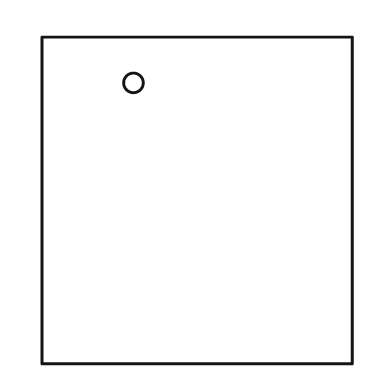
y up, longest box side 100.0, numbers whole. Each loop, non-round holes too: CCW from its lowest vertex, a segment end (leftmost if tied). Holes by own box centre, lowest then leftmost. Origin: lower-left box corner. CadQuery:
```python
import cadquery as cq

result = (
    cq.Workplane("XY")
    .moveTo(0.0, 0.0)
    .lineTo(95.0, 0.0)
    .lineTo(95.0, 100.0)
    .lineTo(0.0, 100.0)
    .close()
    .moveTo(28.0, 86.0)
    .circle(3.0)
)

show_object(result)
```